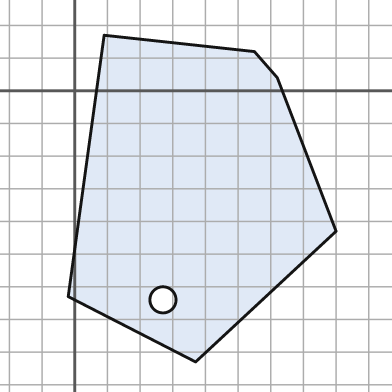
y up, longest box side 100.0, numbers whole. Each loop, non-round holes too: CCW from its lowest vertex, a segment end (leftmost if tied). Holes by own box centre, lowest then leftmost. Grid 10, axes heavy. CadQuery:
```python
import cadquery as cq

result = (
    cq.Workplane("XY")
    .moveTo(37.0, -83.0)
    .lineTo(80.0, -43.0)
    .lineTo(62.0, 4.0)
    .lineTo(55.0, 12.0)
    .lineTo(9.0, 17.0)
    .lineTo(-2.0, -63.0)
    .close()
    .moveTo(27.0, -64.0)
    .circle(4.0)
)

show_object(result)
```